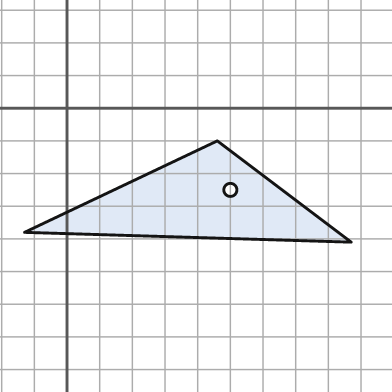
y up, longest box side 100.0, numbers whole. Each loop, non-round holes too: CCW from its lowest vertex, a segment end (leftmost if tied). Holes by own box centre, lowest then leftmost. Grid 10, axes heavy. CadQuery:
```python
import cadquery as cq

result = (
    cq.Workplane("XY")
    .moveTo(87.0, -41.0)
    .lineTo(46.0, -10.0)
    .lineTo(-13.0, -38.0)
    .close()
    .moveTo(50.0, -25.0)
    .circle(2.0)
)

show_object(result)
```